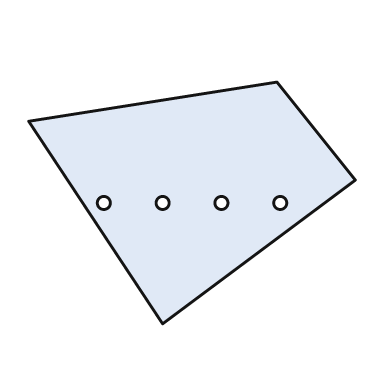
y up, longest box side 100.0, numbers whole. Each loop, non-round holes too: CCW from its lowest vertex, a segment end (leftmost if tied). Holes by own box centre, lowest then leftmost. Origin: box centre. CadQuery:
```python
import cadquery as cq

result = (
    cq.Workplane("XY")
    .moveTo(-9.0, -37.0)
    .lineTo(50.0, 7.0)
    .lineTo(26.0, 37.0)
    .lineTo(-50.0, 25.0)
    .close()
    .moveTo(-27.0, 0.0)
    .circle(2.0)
    .moveTo(-9.0, 0.0)
    .circle(2.0)
    .moveTo(9.0, 0.0)
    .circle(2.0)
    .moveTo(27.0, 0.0)
    .circle(2.0)
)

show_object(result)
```